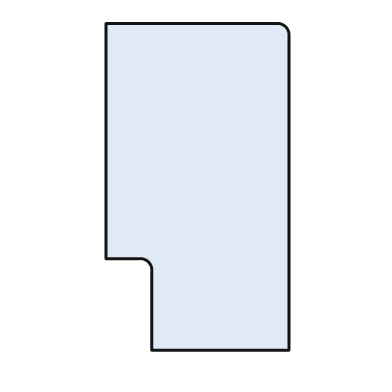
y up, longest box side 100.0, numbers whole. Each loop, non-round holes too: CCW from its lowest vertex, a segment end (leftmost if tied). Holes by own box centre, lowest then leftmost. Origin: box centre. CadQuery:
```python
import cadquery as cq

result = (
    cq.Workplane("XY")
    .moveTo(-14.0, -50.0)
    .lineTo(28.0, -50.0)
    .lineTo(28.0, 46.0)
    .threePointArc((27.0, 49.0), (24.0, 50.0))
    .lineTo(-28.0, 50.0)
    .lineTo(-28.0, -22.0)
    .lineTo(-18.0, -22.0)
    .threePointArc((-15.0, -23.0), (-14.0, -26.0))
    .close()
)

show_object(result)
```